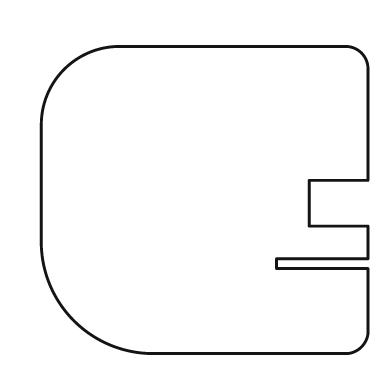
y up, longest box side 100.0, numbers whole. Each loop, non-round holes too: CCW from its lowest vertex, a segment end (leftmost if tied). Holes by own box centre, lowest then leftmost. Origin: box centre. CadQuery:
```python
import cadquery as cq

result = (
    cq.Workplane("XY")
    .moveTo(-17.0, -47.0)
    .lineTo(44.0, -47.0)
    .threePointArc((48.0, -45.0), (50.0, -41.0))
    .lineTo(50.0, -21.0)
    .lineTo(22.0, -21.0)
    .lineTo(22.0, -18.0)
    .lineTo(50.0, -18.0)
    .lineTo(50.0, -8.0)
    .lineTo(32.0, -8.0)
    .lineTo(32.0, 6.0)
    .lineTo(50.0, 6.0)
    .lineTo(50.0, 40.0)
    .threePointArc((48.0, 45.0), (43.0, 47.0))
    .lineTo(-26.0, 47.0)
    .threePointArc((-43.0, 40.0), (-50.0, 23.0))
    .lineTo(-50.0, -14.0)
    .threePointArc((-40.0, -37.0), (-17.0, -47.0))
    .close()
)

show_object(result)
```